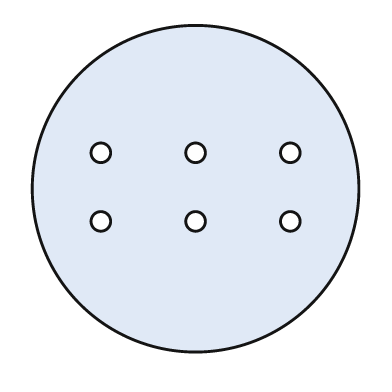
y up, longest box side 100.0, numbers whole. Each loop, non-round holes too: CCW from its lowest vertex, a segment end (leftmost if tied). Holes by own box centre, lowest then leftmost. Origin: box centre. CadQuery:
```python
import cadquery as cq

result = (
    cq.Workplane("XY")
    .moveTo(0.0, 0.0)
    .circle(50.0)
    .moveTo(-29.0, -10.0)
    .circle(3.0)
    .moveTo(0.0, -10.0)
    .circle(3.0)
    .moveTo(29.0, -10.0)
    .circle(3.0)
    .moveTo(-29.0, 11.0)
    .circle(3.0)
    .moveTo(0.0, 11.0)
    .circle(3.0)
    .moveTo(29.0, 11.0)
    .circle(3.0)
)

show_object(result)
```